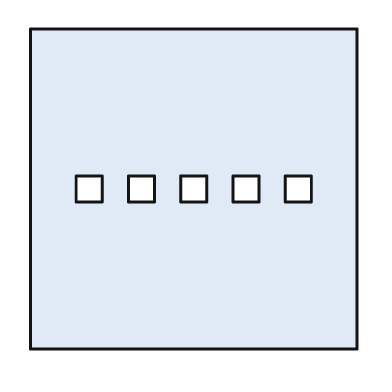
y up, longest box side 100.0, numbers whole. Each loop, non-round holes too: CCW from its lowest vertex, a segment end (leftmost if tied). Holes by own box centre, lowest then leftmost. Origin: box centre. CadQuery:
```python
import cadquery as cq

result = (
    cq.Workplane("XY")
    .moveTo(-50.0, -49.0)
    .lineTo(50.0, -49.0)
    .lineTo(50.0, 49.0)
    .lineTo(-50.0, 49.0)
    .close()
    .moveTo(-36.0, -4.0)
    .lineTo(-28.0, -4.0)
    .lineTo(-28.0, 4.0)
    .lineTo(-36.0, 4.0)
    .close()
    .moveTo(-20.0, -4.0)
    .lineTo(-12.0, -4.0)
    .lineTo(-12.0, 4.0)
    .lineTo(-20.0, 4.0)
    .close()
    .moveTo(-4.0, -4.0)
    .lineTo(4.0, -4.0)
    .lineTo(4.0, 4.0)
    .lineTo(-4.0, 4.0)
    .close()
    .moveTo(12.0, -4.0)
    .lineTo(20.0, -4.0)
    .lineTo(20.0, 4.0)
    .lineTo(12.0, 4.0)
    .close()
    .moveTo(28.0, -4.0)
    .lineTo(36.0, -4.0)
    .lineTo(36.0, 4.0)
    .lineTo(28.0, 4.0)
    .close()
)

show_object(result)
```